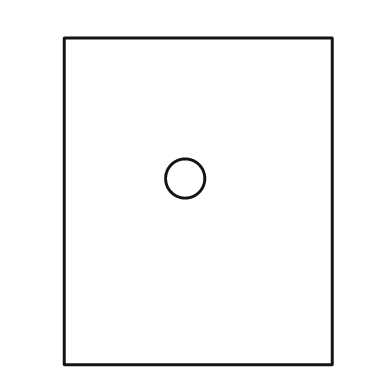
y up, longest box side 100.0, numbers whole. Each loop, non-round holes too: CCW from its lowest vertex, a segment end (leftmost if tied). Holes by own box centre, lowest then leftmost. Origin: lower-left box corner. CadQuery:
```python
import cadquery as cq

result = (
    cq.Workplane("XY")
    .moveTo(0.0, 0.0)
    .lineTo(82.0, 0.0)
    .lineTo(82.0, 100.0)
    .lineTo(0.0, 100.0)
    .close()
    .moveTo(37.0, 57.0)
    .circle(6.0)
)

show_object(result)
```